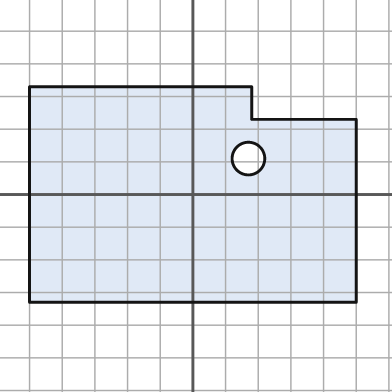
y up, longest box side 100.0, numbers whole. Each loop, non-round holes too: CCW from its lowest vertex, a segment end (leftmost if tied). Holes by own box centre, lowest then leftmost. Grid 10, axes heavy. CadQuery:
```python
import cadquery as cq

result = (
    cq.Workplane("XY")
    .moveTo(-50.0, -33.0)
    .lineTo(50.0, -33.0)
    .lineTo(50.0, 23.0)
    .lineTo(18.0, 23.0)
    .lineTo(18.0, 33.0)
    .lineTo(-50.0, 33.0)
    .close()
    .moveTo(17.0, 11.0)
    .circle(5.0)
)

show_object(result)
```